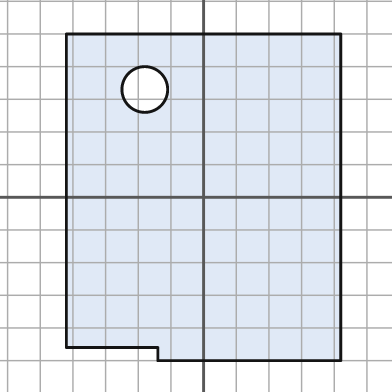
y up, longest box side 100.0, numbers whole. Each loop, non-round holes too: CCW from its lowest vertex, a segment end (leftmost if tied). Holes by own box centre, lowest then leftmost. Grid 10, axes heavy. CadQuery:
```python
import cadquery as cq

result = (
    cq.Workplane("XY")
    .moveTo(-14.0, -50.0)
    .lineTo(42.0, -50.0)
    .lineTo(42.0, 50.0)
    .lineTo(-42.0, 50.0)
    .lineTo(-42.0, -46.0)
    .lineTo(-14.0, -46.0)
    .close()
    .moveTo(-18.0, 33.0)
    .circle(7.0)
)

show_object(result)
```